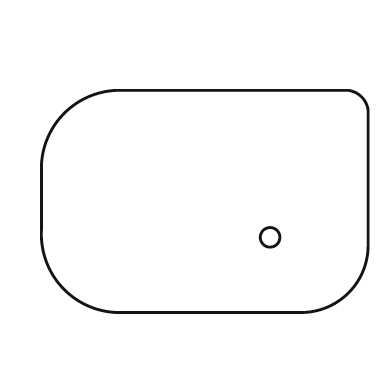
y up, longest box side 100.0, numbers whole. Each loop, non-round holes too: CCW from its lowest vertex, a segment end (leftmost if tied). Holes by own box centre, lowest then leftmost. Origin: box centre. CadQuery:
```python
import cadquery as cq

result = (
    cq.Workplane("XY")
    .moveTo(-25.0, -34.0)
    .lineTo(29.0, -34.0)
    .threePointArc((44.0, -28.0), (50.0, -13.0))
    .lineTo(50.0, 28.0)
    .threePointArc((48.0, 32.0), (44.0, 34.0))
    .lineTo(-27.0, 34.0)
    .threePointArc((-43.0, 27.0), (-50.0, 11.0))
    .lineTo(-50.0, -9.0)
    .threePointArc((-43.0, -27.0), (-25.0, -34.0))
    .close()
    .moveTo(20.0, -11.0)
    .circle(3.0)
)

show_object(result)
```